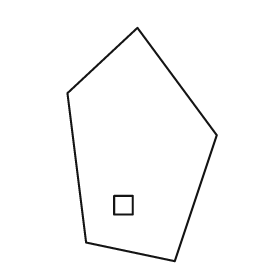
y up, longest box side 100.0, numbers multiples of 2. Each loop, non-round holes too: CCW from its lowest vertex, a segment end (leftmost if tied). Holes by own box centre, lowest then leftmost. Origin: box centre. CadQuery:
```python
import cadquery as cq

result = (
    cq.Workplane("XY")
    .moveTo(14.0, -50.0)
    .lineTo(32.0, 4.0)
    .lineTo(-2.0, 50.0)
    .lineTo(-32.0, 22.0)
    .lineTo(-24.0, -42.0)
    .close()
    .moveTo(-12.0, -30.0)
    .lineTo(-4.0, -30.0)
    .lineTo(-4.0, -22.0)
    .lineTo(-12.0, -22.0)
    .close()
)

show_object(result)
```